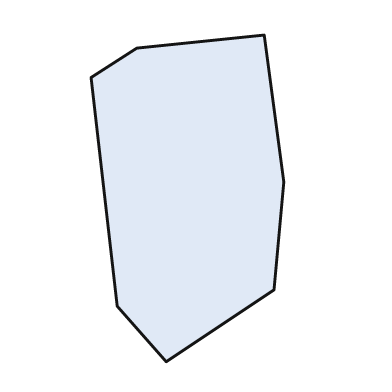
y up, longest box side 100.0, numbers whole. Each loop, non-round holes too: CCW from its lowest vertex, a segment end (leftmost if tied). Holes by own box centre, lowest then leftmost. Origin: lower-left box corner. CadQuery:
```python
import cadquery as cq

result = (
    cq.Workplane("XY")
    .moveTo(23.0, 0.0)
    .lineTo(56.0, 22.0)
    .lineTo(59.0, 55.0)
    .lineTo(53.0, 100.0)
    .lineTo(14.0, 96.0)
    .lineTo(0.0, 87.0)
    .lineTo(8.0, 17.0)
    .close()
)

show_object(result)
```